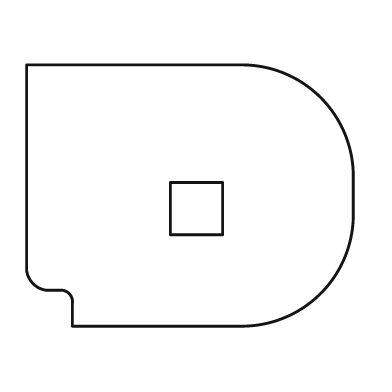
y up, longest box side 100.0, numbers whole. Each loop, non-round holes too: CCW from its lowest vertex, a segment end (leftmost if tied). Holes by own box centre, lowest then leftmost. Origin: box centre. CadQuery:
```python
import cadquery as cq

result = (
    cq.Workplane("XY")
    .moveTo(-36.0, -40.0)
    .lineTo(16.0, -40.0)
    .threePointArc((40.0, -30.0), (50.0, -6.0))
    .lineTo(50.0, 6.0)
    .threePointArc((40.0, 30.0), (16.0, 40.0))
    .lineTo(-50.0, 40.0)
    .lineTo(-50.0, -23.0)
    .threePointArc((-48.0, -27.0), (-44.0, -29.0))
    .lineTo(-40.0, -29.0)
    .threePointArc((-37.0, -30.0), (-36.0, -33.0))
    .close()
    .moveTo(-6.0, -12.0)
    .lineTo(10.0, -12.0)
    .lineTo(10.0, 4.0)
    .lineTo(-6.0, 4.0)
    .close()
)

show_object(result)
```